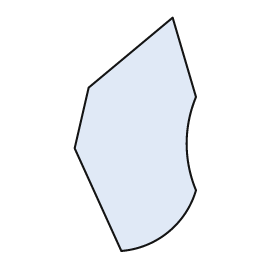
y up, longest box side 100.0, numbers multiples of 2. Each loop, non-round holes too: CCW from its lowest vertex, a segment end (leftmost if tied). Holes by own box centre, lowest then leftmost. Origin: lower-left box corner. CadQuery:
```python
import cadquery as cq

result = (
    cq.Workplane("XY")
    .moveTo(20.0, 0.0)
    .threePointArc((40.0, 8.0), (52.0, 26.0))
    .threePointArc((48.0, 46.0), (52.0, 66.0))
    .lineTo(42.0, 100.0)
    .lineTo(6.0, 70.0)
    .lineTo(0.0, 44.0)
    .close()
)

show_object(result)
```